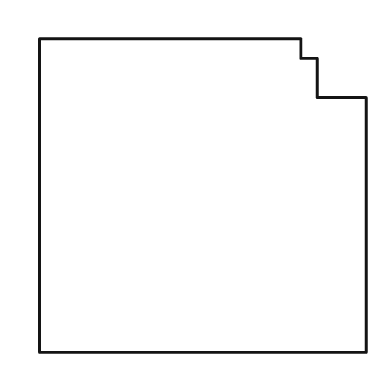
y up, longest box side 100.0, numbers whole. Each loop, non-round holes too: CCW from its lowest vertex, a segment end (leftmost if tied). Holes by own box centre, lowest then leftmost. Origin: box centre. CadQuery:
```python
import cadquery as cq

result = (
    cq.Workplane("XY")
    .moveTo(-50.0, -48.0)
    .lineTo(50.0, -48.0)
    .lineTo(50.0, 30.0)
    .lineTo(35.0, 30.0)
    .lineTo(35.0, 42.0)
    .lineTo(30.0, 42.0)
    .lineTo(30.0, 48.0)
    .lineTo(-50.0, 48.0)
    .close()
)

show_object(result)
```